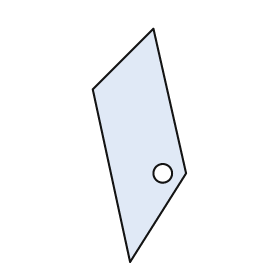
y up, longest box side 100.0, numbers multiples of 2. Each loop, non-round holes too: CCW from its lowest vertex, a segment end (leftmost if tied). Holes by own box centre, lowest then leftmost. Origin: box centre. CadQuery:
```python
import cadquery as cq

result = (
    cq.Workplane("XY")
    .moveTo(-4.0, -50.0)
    .lineTo(20.0, -12.0)
    .lineTo(6.0, 50.0)
    .lineTo(-20.0, 24.0)
    .close()
    .moveTo(10.0, -12.0)
    .circle(4.0)
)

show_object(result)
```